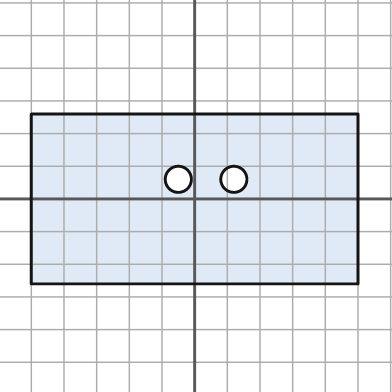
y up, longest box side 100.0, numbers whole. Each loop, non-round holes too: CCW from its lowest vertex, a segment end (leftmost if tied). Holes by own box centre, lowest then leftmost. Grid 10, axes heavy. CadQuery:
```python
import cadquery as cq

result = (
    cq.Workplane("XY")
    .moveTo(-50.0, -26.0)
    .lineTo(50.0, -26.0)
    .lineTo(50.0, 26.0)
    .lineTo(-50.0, 26.0)
    .close()
    .moveTo(-5.0, 6.0)
    .circle(4.0)
    .moveTo(12.0, 6.0)
    .circle(4.0)
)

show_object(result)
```